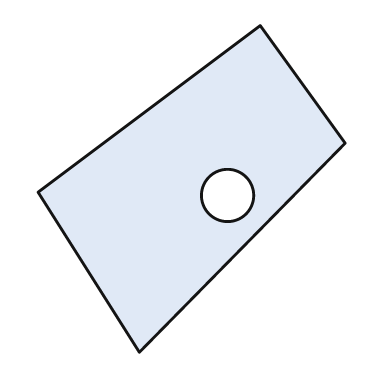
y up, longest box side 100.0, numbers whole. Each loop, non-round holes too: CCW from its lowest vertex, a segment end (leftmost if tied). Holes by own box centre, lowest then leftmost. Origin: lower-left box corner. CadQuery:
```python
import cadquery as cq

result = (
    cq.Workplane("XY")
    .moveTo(31.0, 0.0)
    .lineTo(94.0, 64.0)
    .lineTo(68.0, 100.0)
    .lineTo(0.0, 49.0)
    .close()
    .moveTo(58.0, 48.0)
    .circle(8.0)
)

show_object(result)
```